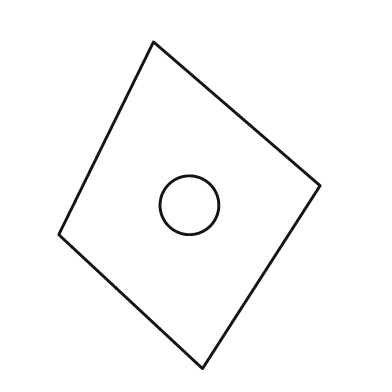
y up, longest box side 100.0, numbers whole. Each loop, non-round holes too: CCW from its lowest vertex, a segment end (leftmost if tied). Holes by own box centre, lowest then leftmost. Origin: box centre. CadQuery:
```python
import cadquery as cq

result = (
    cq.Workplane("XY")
    .moveTo(4.0, -50.0)
    .lineTo(40.0, 6.0)
    .lineTo(-11.0, 50.0)
    .lineTo(-40.0, -9.0)
    .close()
    .moveTo(0.0, 0.0)
    .circle(9.0)
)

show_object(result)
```